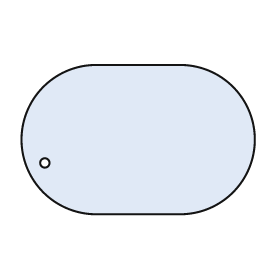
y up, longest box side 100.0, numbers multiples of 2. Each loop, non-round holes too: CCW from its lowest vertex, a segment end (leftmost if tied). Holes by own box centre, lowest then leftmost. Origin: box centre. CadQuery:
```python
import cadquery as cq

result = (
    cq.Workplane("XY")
    .moveTo(-18.0, -32.0)
    .lineTo(18.0, -32.0)
    .threePointArc((50.0, 0.0), (18.0, 32.0))
    .lineTo(-18.0, 32.0)
    .threePointArc((-50.0, 0.0), (-18.0, -32.0))
    .close()
    .moveTo(-40.0, -10.0)
    .circle(2.0)
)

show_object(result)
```